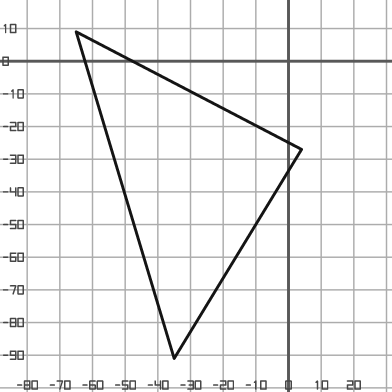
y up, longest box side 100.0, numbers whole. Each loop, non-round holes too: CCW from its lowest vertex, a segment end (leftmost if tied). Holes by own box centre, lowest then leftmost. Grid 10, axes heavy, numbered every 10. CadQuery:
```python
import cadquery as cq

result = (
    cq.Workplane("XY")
    .moveTo(-35.0, -91.0)
    .lineTo(4.0, -27.0)
    .lineTo(-65.0, 9.0)
    .close()
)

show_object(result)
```